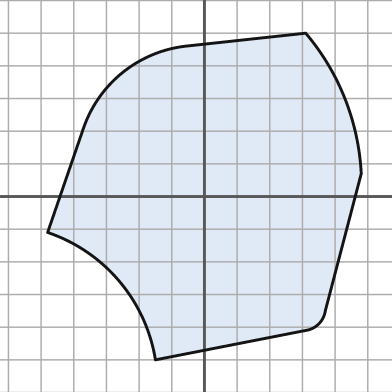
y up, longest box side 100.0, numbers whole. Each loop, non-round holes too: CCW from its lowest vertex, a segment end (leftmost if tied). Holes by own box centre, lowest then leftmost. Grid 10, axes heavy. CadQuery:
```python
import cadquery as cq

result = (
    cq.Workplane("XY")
    .moveTo(-15.0, -50.0)
    .lineTo(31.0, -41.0)
    .threePointArc((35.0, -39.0), (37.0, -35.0))
    .lineTo(48.0, 7.0)
    .threePointArc((43.0, 30.0), (31.0, 50.0))
    .lineTo(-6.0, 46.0)
    .threePointArc((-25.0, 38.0), (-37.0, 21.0))
    .lineTo(-48.0, -11.0)
    .threePointArc((-26.0, -26.0), (-15.0, -50.0))
    .close()
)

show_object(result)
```